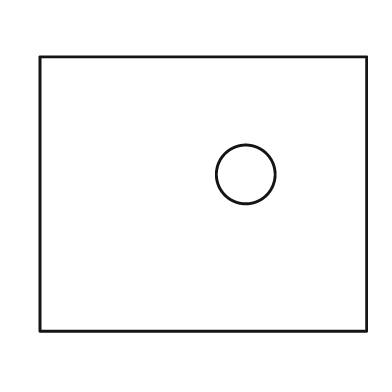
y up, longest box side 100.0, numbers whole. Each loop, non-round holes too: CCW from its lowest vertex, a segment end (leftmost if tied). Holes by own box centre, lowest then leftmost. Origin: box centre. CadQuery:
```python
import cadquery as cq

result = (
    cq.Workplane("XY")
    .moveTo(-50.0, -42.0)
    .lineTo(50.0, -42.0)
    .lineTo(50.0, 42.0)
    .lineTo(-50.0, 42.0)
    .close()
    .moveTo(13.0, 6.0)
    .circle(9.0)
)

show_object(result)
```